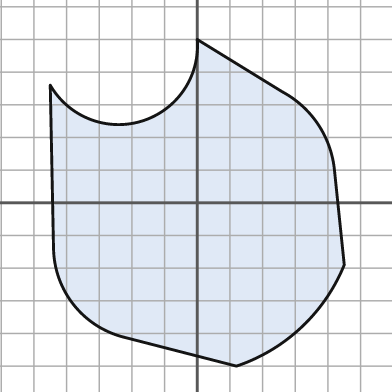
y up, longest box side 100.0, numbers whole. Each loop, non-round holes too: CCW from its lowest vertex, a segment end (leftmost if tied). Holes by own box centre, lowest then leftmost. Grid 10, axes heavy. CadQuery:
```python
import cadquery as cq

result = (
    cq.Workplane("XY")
    .moveTo(12.0, -50.0)
    .threePointArc((32.0, -38.0), (45.0, -19.0))
    .lineTo(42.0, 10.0)
    .threePointArc((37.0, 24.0), (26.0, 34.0))
    .lineTo(0.0, 50.0)
    .threePointArc((-17.0, 25.0), (-45.0, 36.0))
    .lineTo(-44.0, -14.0)
    .threePointArc((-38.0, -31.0), (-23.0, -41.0))
    .close()
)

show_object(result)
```